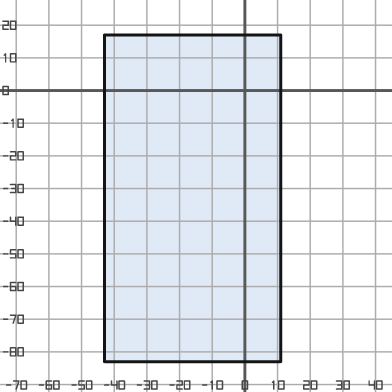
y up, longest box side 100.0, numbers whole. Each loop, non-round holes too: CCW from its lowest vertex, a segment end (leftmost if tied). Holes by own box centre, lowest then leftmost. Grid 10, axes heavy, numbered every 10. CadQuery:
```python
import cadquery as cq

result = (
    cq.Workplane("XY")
    .moveTo(-43.0, -83.0)
    .lineTo(11.0, -83.0)
    .lineTo(11.0, 17.0)
    .lineTo(-43.0, 17.0)
    .close()
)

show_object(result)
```